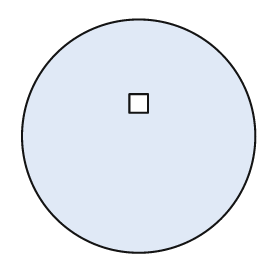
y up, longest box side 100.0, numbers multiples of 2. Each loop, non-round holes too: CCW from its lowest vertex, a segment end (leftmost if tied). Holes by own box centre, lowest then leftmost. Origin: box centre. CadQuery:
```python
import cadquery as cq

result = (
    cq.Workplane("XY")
    .moveTo(0.0, 0.0)
    .circle(50.0)
    .moveTo(-4.0, 10.0)
    .lineTo(4.0, 10.0)
    .lineTo(4.0, 18.0)
    .lineTo(-4.0, 18.0)
    .close()
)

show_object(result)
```